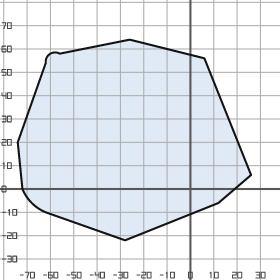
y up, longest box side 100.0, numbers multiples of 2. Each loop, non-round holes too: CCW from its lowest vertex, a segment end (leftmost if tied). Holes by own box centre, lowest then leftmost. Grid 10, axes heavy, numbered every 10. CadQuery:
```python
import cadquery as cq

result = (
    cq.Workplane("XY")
    .moveTo(-28.0, -22.0)
    .lineTo(12.0, -6.0)
    .lineTo(26.0, 6.0)
    .lineTo(6.0, 56.0)
    .lineTo(-26.0, 64.0)
    .lineTo(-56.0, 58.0)
    .threePointArc((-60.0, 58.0), (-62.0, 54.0))
    .lineTo(-74.0, 20.0)
    .lineTo(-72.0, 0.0)
    .threePointArc((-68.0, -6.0), (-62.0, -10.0))
    .close()
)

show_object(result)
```